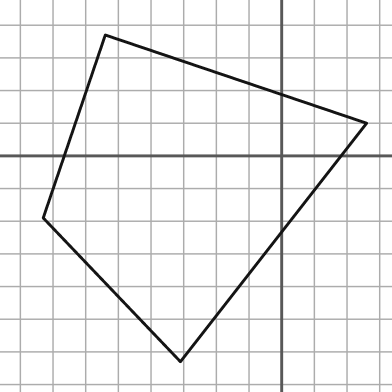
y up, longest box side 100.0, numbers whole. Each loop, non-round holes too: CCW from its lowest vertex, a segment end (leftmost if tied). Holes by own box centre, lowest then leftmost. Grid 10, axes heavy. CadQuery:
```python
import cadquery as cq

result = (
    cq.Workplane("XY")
    .moveTo(-31.0, -63.0)
    .lineTo(26.0, 10.0)
    .lineTo(-54.0, 37.0)
    .lineTo(-73.0, -19.0)
    .close()
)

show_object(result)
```